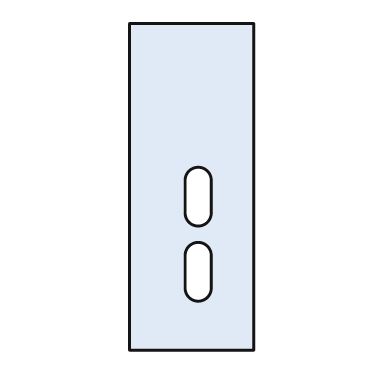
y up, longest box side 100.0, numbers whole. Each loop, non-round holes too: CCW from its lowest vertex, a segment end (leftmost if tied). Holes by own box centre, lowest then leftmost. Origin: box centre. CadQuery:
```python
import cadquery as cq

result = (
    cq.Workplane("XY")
    .moveTo(-19.0, -50.0)
    .lineTo(19.0, -50.0)
    .lineTo(19.0, 50.0)
    .lineTo(-19.0, 50.0)
    .close()
    .moveTo(-2.0, -31.0)
    .threePointArc((2.0, -35.0), (6.0, -31.0))
    .lineTo(6.0, -21.0)
    .threePointArc((2.0, -17.0), (-2.0, -21.0))
    .close()
    .moveTo(-2.0, -8.0)
    .threePointArc((2.0, -12.0), (6.0, -8.0))
    .lineTo(6.0, 2.0)
    .threePointArc((2.0, 6.0), (-2.0, 2.0))
    .close()
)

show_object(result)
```